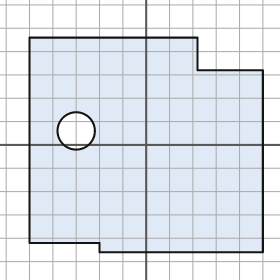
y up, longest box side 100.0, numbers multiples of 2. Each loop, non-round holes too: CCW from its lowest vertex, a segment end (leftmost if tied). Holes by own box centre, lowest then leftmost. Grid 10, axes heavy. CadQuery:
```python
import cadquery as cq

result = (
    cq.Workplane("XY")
    .moveTo(-20.0, -46.0)
    .lineTo(50.0, -46.0)
    .lineTo(50.0, 32.0)
    .lineTo(22.0, 32.0)
    .lineTo(22.0, 46.0)
    .lineTo(-50.0, 46.0)
    .lineTo(-50.0, -42.0)
    .lineTo(-20.0, -42.0)
    .close()
    .moveTo(-30.0, 6.0)
    .circle(8.0)
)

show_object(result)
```